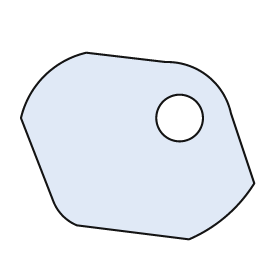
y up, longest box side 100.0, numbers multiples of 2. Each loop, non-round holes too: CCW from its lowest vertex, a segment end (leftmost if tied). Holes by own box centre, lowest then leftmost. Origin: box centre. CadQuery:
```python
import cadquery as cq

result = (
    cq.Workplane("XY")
    .moveTo(22.0, -40.0)
    .threePointArc((38.0, -30.0), (50.0, -16.0))
    .lineTo(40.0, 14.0)
    .threePointArc((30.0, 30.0), (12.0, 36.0))
    .lineTo(-22.0, 40.0)
    .threePointArc((-40.0, 30.0), (-50.0, 12.0))
    .lineTo(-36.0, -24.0)
    .threePointArc((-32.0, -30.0), (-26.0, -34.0))
    .close()
    .moveTo(18.0, 12.0)
    .circle(10.0)
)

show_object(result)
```